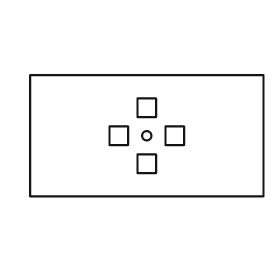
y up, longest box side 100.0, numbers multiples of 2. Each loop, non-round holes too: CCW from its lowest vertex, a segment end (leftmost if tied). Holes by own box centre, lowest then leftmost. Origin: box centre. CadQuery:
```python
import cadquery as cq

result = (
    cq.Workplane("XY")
    .moveTo(-50.0, -26.0)
    .lineTo(50.0, -26.0)
    .lineTo(50.0, 26.0)
    .lineTo(-50.0, 26.0)
    .close()
    .moveTo(-4.0, -16.0)
    .lineTo(4.0, -16.0)
    .lineTo(4.0, -8.0)
    .lineTo(-4.0, -8.0)
    .close()
    .moveTo(-16.0, -4.0)
    .lineTo(-8.0, -4.0)
    .lineTo(-8.0, 4.0)
    .lineTo(-16.0, 4.0)
    .close()
    .moveTo(0.0, 0.0)
    .circle(2.0)
    .moveTo(8.0, -4.0)
    .lineTo(16.0, -4.0)
    .lineTo(16.0, 4.0)
    .lineTo(8.0, 4.0)
    .close()
    .moveTo(-4.0, 8.0)
    .lineTo(4.0, 8.0)
    .lineTo(4.0, 16.0)
    .lineTo(-4.0, 16.0)
    .close()
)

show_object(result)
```